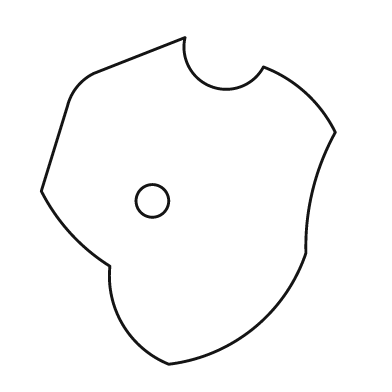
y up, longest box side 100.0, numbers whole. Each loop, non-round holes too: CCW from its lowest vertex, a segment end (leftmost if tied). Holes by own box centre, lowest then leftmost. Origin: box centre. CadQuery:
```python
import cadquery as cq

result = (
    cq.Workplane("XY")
    .moveTo(-6.0, -50.0)
    .threePointArc((20.0, -39.0), (36.0, -16.0))
    .threePointArc((38.0, 3.0), (45.0, 21.0))
    .threePointArc((36.0, 33.0), (23.0, 41.0))
    .threePointArc((7.0, 35.0), (-1.0, 50.0))
    .lineTo(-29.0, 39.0)
    .threePointArc((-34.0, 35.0), (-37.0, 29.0))
    .lineTo(-45.0, 3.0)
    .threePointArc((-36.0, -10.0), (-24.0, -20.0))
    .threePointArc((-20.0, -38.0), (-6.0, -50.0))
    .close()
    .moveTo(-11.0, 0.0)
    .circle(5.0)
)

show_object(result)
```